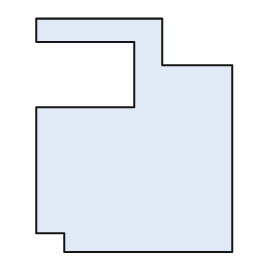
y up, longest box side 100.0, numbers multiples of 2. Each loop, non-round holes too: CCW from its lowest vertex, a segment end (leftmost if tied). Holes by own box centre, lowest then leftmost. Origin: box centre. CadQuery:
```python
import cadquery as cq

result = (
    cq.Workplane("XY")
    .moveTo(-30.0, -50.0)
    .lineTo(42.0, -50.0)
    .lineTo(42.0, 30.0)
    .lineTo(12.0, 30.0)
    .lineTo(12.0, 50.0)
    .lineTo(-42.0, 50.0)
    .lineTo(-42.0, 40.0)
    .lineTo(0.0, 40.0)
    .lineTo(0.0, 12.0)
    .lineTo(-42.0, 12.0)
    .lineTo(-42.0, -42.0)
    .lineTo(-30.0, -42.0)
    .close()
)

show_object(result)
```